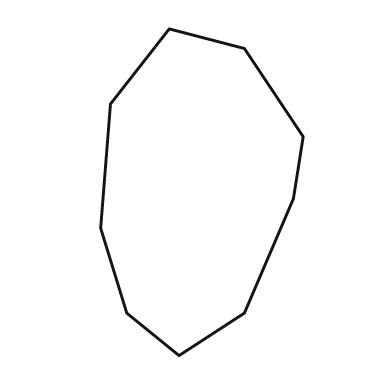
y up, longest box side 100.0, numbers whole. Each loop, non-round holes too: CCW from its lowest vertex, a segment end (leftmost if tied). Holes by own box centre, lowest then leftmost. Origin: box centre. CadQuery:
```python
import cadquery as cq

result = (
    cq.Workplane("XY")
    .moveTo(-7.0, -50.0)
    .lineTo(13.0, -37.0)
    .lineTo(28.0, -2.0)
    .lineTo(31.0, 17.0)
    .lineTo(13.0, 44.0)
    .lineTo(-10.0, 50.0)
    .lineTo(-28.0, 27.0)
    .lineTo(-31.0, -11.0)
    .lineTo(-23.0, -37.0)
    .close()
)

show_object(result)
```